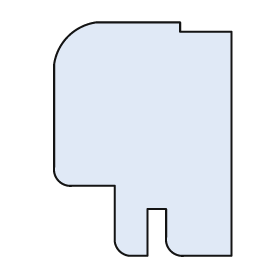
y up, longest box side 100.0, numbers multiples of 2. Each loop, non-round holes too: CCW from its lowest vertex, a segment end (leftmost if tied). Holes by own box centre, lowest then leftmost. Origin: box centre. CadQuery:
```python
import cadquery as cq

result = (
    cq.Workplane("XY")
    .moveTo(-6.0, -50.0)
    .lineTo(2.0, -50.0)
    .lineTo(2.0, -30.0)
    .lineTo(10.0, -30.0)
    .lineTo(10.0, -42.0)
    .threePointArc((12.0, -48.0), (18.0, -50.0))
    .lineTo(38.0, -50.0)
    .lineTo(38.0, 46.0)
    .lineTo(16.0, 46.0)
    .lineTo(16.0, 50.0)
    .lineTo(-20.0, 50.0)
    .threePointArc((-32.0, 44.0), (-38.0, 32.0))
    .lineTo(-38.0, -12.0)
    .threePointArc((-36.0, -18.0), (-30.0, -20.0))
    .lineTo(-12.0, -20.0)
    .lineTo(-12.0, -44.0)
    .threePointArc((-10.0, -48.0), (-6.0, -50.0))
    .close()
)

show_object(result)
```